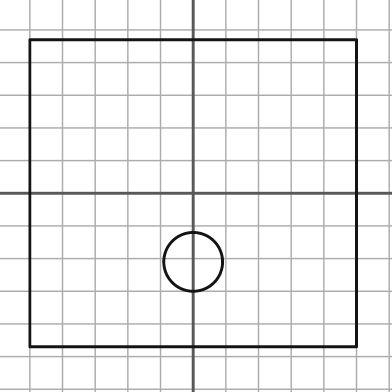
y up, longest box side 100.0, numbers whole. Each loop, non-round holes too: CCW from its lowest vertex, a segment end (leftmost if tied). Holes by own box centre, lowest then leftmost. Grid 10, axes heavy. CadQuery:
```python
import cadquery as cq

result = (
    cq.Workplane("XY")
    .moveTo(-50.0, -47.0)
    .lineTo(50.0, -47.0)
    .lineTo(50.0, 47.0)
    .lineTo(-50.0, 47.0)
    .close()
    .moveTo(0.0, -21.0)
    .circle(9.0)
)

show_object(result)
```